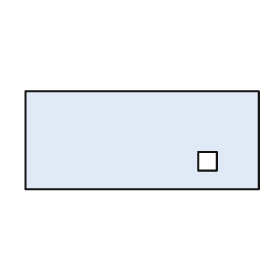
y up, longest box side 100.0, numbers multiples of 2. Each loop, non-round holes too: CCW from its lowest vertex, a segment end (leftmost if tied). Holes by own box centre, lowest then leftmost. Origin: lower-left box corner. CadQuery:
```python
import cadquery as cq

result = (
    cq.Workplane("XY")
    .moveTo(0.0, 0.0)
    .lineTo(100.0, 0.0)
    .lineTo(100.0, 42.0)
    .lineTo(0.0, 42.0)
    .close()
    .moveTo(74.0, 8.0)
    .lineTo(82.0, 8.0)
    .lineTo(82.0, 16.0)
    .lineTo(74.0, 16.0)
    .close()
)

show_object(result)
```